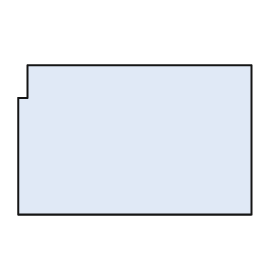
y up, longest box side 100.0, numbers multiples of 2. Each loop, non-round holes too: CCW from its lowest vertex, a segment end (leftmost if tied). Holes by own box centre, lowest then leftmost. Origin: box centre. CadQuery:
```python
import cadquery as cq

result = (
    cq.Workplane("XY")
    .moveTo(-50.0, -32.0)
    .lineTo(50.0, -32.0)
    .lineTo(50.0, 32.0)
    .lineTo(-46.0, 32.0)
    .lineTo(-46.0, 18.0)
    .lineTo(-50.0, 18.0)
    .close()
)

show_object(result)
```